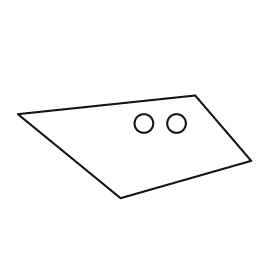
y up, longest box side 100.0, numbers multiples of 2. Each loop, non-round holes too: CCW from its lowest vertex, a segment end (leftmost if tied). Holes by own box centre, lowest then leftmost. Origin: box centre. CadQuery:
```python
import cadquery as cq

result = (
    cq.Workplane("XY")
    .moveTo(-6.0, -22.0)
    .lineTo(50.0, -6.0)
    .lineTo(26.0, 22.0)
    .lineTo(-50.0, 14.0)
    .close()
    .moveTo(4.0, 10.0)
    .circle(4.0)
    .moveTo(18.0, 10.0)
    .circle(4.0)
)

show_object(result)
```